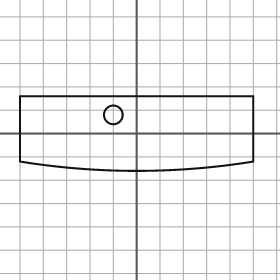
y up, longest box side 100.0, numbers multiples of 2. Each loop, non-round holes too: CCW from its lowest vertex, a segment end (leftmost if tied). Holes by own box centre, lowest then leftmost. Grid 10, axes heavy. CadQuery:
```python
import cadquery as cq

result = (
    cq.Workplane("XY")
    .moveTo(-50.0, -12.0)
    .threePointArc((0.0, -16.0), (50.0, -12.0))
    .lineTo(50.0, 16.0)
    .lineTo(-50.0, 16.0)
    .close()
    .moveTo(-10.0, 8.0)
    .circle(4.0)
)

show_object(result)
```